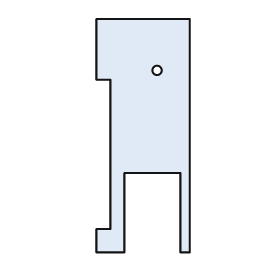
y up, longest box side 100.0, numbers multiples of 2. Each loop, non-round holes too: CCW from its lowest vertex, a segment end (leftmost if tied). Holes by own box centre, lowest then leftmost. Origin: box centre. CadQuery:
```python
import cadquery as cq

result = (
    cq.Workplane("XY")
    .moveTo(-20.0, -50.0)
    .lineTo(-8.0, -50.0)
    .lineTo(-8.0, -16.0)
    .lineTo(16.0, -16.0)
    .lineTo(16.0, -50.0)
    .lineTo(20.0, -50.0)
    .lineTo(20.0, 50.0)
    .lineTo(-20.0, 50.0)
    .lineTo(-20.0, 24.0)
    .lineTo(-14.0, 24.0)
    .lineTo(-14.0, -40.0)
    .lineTo(-20.0, -40.0)
    .close()
    .moveTo(6.0, 28.0)
    .circle(2.0)
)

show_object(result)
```